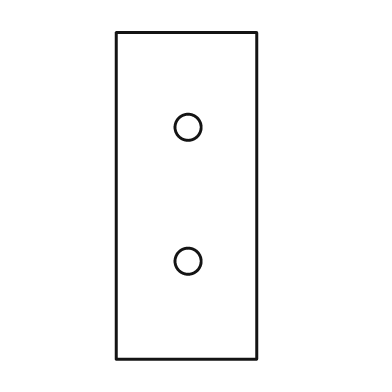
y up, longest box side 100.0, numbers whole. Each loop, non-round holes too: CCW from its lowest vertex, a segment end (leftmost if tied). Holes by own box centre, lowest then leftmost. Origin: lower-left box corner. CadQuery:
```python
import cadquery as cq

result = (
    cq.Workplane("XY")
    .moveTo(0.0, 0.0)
    .lineTo(43.0, 0.0)
    .lineTo(43.0, 100.0)
    .lineTo(0.0, 100.0)
    .close()
    .moveTo(22.0, 30.0)
    .circle(4.0)
    .moveTo(22.0, 71.0)
    .circle(4.0)
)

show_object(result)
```